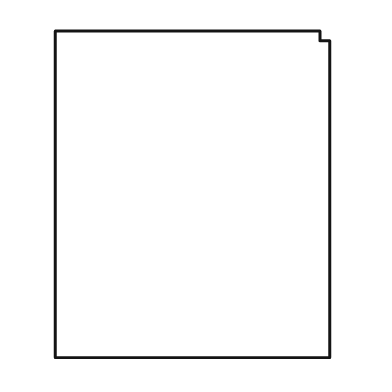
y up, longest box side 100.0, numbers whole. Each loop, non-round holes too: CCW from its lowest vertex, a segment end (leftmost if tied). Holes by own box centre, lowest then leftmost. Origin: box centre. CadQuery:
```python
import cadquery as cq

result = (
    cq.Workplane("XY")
    .moveTo(-42.0, -50.0)
    .lineTo(42.0, -50.0)
    .lineTo(42.0, 47.0)
    .lineTo(39.0, 47.0)
    .lineTo(39.0, 50.0)
    .lineTo(-42.0, 50.0)
    .close()
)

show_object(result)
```